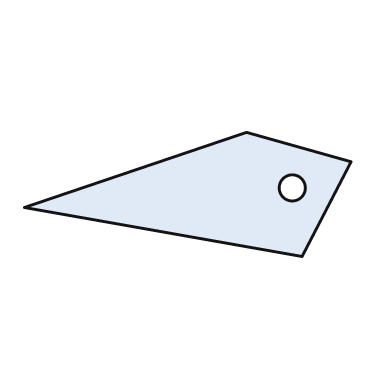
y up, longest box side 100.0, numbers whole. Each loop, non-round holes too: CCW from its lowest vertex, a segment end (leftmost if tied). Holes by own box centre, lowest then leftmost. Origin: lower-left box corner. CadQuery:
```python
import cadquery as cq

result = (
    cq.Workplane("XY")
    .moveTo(85.0, 0.0)
    .lineTo(100.0, 29.0)
    .lineTo(68.0, 38.0)
    .lineTo(0.0, 15.0)
    .close()
    .moveTo(82.0, 21.0)
    .circle(4.0)
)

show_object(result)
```